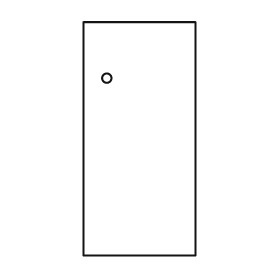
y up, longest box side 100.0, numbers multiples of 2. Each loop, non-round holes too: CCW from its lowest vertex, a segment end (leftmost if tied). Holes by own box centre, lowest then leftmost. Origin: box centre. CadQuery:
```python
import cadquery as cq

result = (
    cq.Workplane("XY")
    .moveTo(-24.0, -50.0)
    .lineTo(24.0, -50.0)
    .lineTo(24.0, 50.0)
    .lineTo(-24.0, 50.0)
    .close()
    .moveTo(-14.0, 26.0)
    .circle(2.0)
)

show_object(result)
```